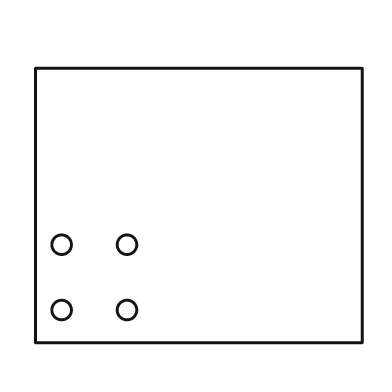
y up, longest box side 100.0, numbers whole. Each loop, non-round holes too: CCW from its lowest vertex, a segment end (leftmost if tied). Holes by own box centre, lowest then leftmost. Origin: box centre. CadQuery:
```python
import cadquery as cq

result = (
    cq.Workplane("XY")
    .moveTo(-50.0, -42.0)
    .lineTo(50.0, -42.0)
    .lineTo(50.0, 42.0)
    .lineTo(-50.0, 42.0)
    .close()
    .moveTo(-42.0, -32.0)
    .circle(3.0)
    .moveTo(-22.0, -32.0)
    .circle(3.0)
    .moveTo(-42.0, -12.0)
    .circle(3.0)
    .moveTo(-22.0, -12.0)
    .circle(3.0)
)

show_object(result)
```